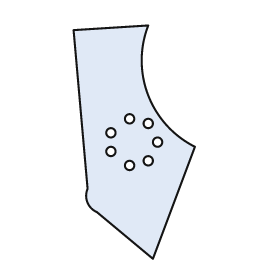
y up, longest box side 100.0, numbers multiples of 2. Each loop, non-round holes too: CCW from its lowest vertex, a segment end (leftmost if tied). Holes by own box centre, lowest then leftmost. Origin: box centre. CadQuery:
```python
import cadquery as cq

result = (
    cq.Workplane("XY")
    .moveTo(8.0, -50.0)
    .lineTo(26.0, -2.0)
    .threePointArc((6.0, 20.0), (6.0, 50.0))
    .lineTo(-26.0, 48.0)
    .lineTo(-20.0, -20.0)
    .threePointArc((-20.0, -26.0), (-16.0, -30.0))
    .close()
    .moveTo(-2.0, -10.0)
    .circle(2.0)
    .moveTo(6.0, -8.0)
    .circle(2.0)
    .moveTo(-10.0, -4.0)
    .circle(2.0)
    .moveTo(10.0, 0.0)
    .circle(2.0)
    .moveTo(-10.0, 4.0)
    .circle(2.0)
    .moveTo(6.0, 8.0)
    .circle(2.0)
    .moveTo(-2.0, 10.0)
    .circle(2.0)
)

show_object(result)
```